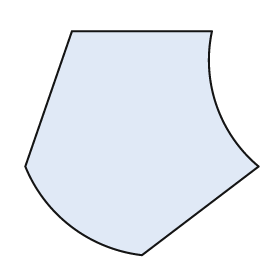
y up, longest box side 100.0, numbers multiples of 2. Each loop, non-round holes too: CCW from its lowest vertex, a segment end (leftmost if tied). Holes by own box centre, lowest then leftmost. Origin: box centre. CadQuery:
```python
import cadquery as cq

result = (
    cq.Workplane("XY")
    .moveTo(0.0, -48.0)
    .lineTo(50.0, -10.0)
    .threePointArc((32.0, 16.0), (30.0, 48.0))
    .lineTo(-30.0, 48.0)
    .lineTo(-50.0, -10.0)
    .threePointArc((-30.0, -36.0), (0.0, -48.0))
    .close()
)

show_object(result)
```